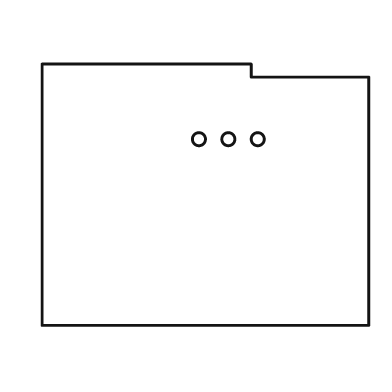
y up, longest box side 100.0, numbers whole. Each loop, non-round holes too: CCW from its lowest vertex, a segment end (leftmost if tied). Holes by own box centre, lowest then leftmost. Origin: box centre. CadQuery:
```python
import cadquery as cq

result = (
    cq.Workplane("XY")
    .moveTo(-50.0, -40.0)
    .lineTo(50.0, -40.0)
    .lineTo(50.0, 36.0)
    .lineTo(14.0, 36.0)
    .lineTo(14.0, 40.0)
    .lineTo(-50.0, 40.0)
    .close()
    .moveTo(-2.0, 17.0)
    .circle(2.0)
    .moveTo(7.0, 17.0)
    .circle(2.0)
    .moveTo(16.0, 17.0)
    .circle(2.0)
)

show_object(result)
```